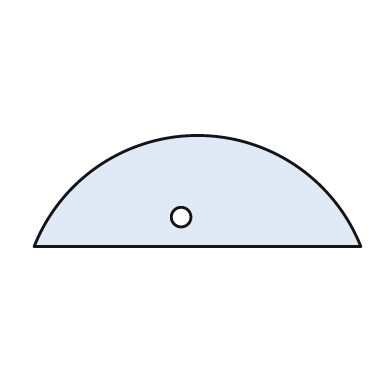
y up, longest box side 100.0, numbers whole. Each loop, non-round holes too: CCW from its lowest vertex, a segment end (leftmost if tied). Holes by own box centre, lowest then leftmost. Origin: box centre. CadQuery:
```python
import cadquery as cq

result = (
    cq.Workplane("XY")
    .moveTo(-50.0, -17.0)
    .lineTo(50.0, -17.0)
    .threePointArc((0.0, 17.0), (-50.0, -17.0))
    .close()
    .moveTo(-5.0, -8.0)
    .circle(3.0)
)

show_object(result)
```